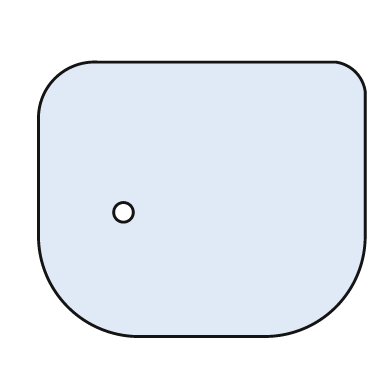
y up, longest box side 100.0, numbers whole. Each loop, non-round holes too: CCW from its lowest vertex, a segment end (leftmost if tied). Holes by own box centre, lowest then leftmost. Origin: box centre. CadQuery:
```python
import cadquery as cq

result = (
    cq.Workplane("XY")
    .moveTo(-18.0, -42.0)
    .lineTo(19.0, -42.0)
    .threePointArc((41.0, -33.0), (50.0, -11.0))
    .lineTo(50.0, 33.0)
    .threePointArc((47.0, 39.0), (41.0, 42.0))
    .lineTo(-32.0, 42.0)
    .threePointArc((-45.0, 37.0), (-50.0, 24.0))
    .lineTo(-50.0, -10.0)
    .threePointArc((-41.0, -33.0), (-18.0, -42.0))
    .close()
    .moveTo(-24.0, -4.0)
    .circle(3.0)
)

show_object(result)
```